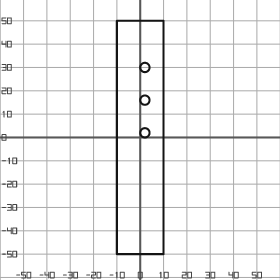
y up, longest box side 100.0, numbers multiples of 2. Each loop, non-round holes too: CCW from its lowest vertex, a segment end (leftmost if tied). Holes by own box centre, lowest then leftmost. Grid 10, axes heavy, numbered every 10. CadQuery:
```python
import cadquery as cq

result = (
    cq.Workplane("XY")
    .moveTo(-10.0, -50.0)
    .lineTo(10.0, -50.0)
    .lineTo(10.0, 50.0)
    .lineTo(-10.0, 50.0)
    .close()
    .moveTo(2.0, 2.0)
    .circle(2.0)
    .moveTo(2.0, 16.0)
    .circle(2.0)
    .moveTo(2.0, 30.0)
    .circle(2.0)
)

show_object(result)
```